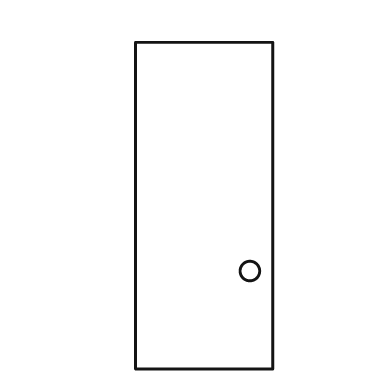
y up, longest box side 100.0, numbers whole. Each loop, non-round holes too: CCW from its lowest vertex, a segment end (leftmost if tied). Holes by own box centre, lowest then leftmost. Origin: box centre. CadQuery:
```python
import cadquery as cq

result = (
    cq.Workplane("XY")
    .moveTo(-21.0, -50.0)
    .lineTo(21.0, -50.0)
    .lineTo(21.0, 50.0)
    .lineTo(-21.0, 50.0)
    .close()
    .moveTo(14.0, -20.0)
    .circle(3.0)
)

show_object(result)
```